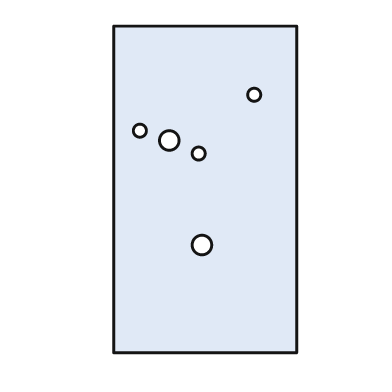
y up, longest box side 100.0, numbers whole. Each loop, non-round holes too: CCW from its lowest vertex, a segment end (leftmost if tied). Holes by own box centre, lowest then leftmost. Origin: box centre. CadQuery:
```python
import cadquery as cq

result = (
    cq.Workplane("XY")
    .moveTo(-28.0, -50.0)
    .lineTo(28.0, -50.0)
    .lineTo(28.0, 50.0)
    .lineTo(-28.0, 50.0)
    .close()
    .moveTo(-1.0, -17.0)
    .circle(3.0)
    .moveTo(-2.0, 11.0)
    .circle(2.0)
    .moveTo(-11.0, 15.0)
    .circle(3.0)
    .moveTo(-20.0, 18.0)
    .circle(2.0)
    .moveTo(15.0, 29.0)
    .circle(2.0)
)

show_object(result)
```